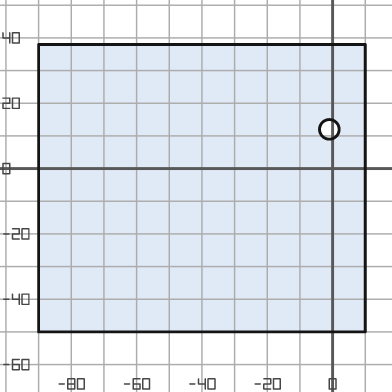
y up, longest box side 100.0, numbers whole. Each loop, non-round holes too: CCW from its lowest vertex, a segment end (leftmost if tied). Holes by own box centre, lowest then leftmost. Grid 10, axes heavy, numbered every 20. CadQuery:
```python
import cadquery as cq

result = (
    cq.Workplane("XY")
    .moveTo(-90.0, -50.0)
    .lineTo(10.0, -50.0)
    .lineTo(10.0, 38.0)
    .lineTo(-90.0, 38.0)
    .close()
    .moveTo(-1.0, 12.0)
    .circle(3.0)
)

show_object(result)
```